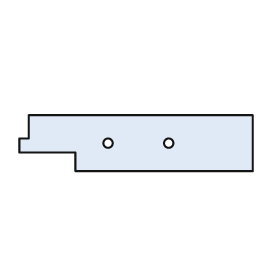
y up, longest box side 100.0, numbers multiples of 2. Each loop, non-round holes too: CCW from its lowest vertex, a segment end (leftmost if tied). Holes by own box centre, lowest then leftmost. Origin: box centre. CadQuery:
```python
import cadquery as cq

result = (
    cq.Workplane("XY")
    .moveTo(-26.0, -12.0)
    .lineTo(50.0, -12.0)
    .lineTo(50.0, 12.0)
    .lineTo(-46.0, 12.0)
    .lineTo(-46.0, 2.0)
    .lineTo(-50.0, 2.0)
    .lineTo(-50.0, -4.0)
    .lineTo(-26.0, -4.0)
    .close()
    .moveTo(-12.0, 0.0)
    .circle(2.0)
    .moveTo(14.0, 0.0)
    .circle(2.0)
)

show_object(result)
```